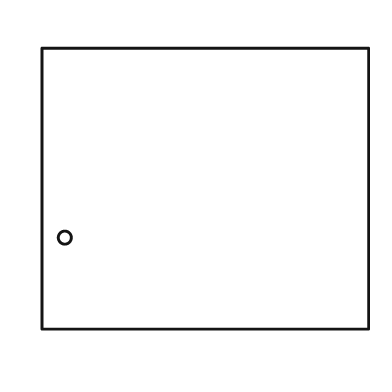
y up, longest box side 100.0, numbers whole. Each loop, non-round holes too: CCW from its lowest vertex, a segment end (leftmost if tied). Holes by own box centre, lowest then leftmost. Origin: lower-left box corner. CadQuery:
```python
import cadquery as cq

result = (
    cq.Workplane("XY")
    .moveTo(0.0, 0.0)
    .lineTo(100.0, 0.0)
    .lineTo(100.0, 86.0)
    .lineTo(0.0, 86.0)
    .close()
    .moveTo(7.0, 28.0)
    .circle(2.0)
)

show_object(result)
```